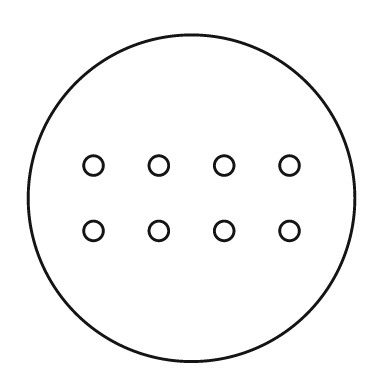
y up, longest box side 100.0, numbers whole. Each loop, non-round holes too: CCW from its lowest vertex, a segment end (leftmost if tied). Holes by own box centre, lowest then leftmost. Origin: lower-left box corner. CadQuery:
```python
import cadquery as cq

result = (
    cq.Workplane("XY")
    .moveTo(50.0, 50.0)
    .circle(50.0)
    .moveTo(20.0, 40.0)
    .circle(3.0)
    .moveTo(40.0, 40.0)
    .circle(3.0)
    .moveTo(60.0, 40.0)
    .circle(3.0)
    .moveTo(80.0, 40.0)
    .circle(3.0)
    .moveTo(20.0, 60.0)
    .circle(3.0)
    .moveTo(40.0, 60.0)
    .circle(3.0)
    .moveTo(60.0, 60.0)
    .circle(3.0)
    .moveTo(80.0, 60.0)
    .circle(3.0)
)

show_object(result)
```